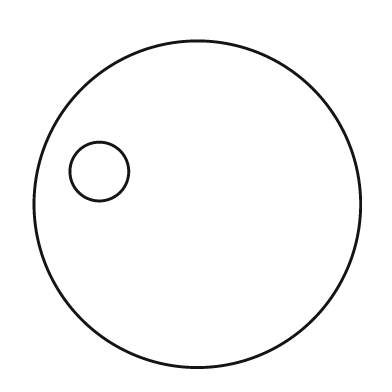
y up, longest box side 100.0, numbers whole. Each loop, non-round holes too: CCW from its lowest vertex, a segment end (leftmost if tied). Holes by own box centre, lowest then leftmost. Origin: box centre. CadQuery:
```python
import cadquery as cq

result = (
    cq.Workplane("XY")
    .moveTo(0.0, 0.0)
    .circle(50.0)
    .moveTo(-30.0, 10.0)
    .circle(9.0)
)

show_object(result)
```